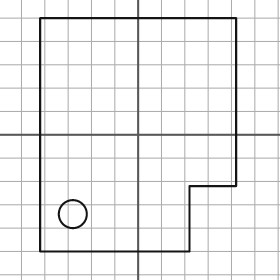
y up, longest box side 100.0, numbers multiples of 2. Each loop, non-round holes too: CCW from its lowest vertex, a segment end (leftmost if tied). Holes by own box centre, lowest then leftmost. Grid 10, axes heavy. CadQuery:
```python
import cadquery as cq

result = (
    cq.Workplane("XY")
    .moveTo(-42.0, -50.0)
    .lineTo(22.0, -50.0)
    .lineTo(22.0, -22.0)
    .lineTo(42.0, -22.0)
    .lineTo(42.0, 50.0)
    .lineTo(-42.0, 50.0)
    .close()
    .moveTo(-28.0, -34.0)
    .circle(6.0)
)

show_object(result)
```